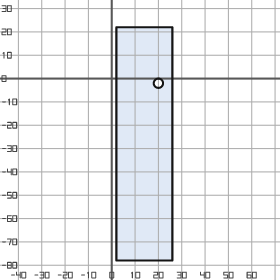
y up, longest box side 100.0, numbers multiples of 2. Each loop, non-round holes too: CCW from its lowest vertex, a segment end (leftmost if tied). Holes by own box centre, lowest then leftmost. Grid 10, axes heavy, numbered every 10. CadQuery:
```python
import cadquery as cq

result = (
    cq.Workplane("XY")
    .moveTo(2.0, -78.0)
    .lineTo(26.0, -78.0)
    .lineTo(26.0, 22.0)
    .lineTo(2.0, 22.0)
    .close()
    .moveTo(20.0, -2.0)
    .circle(2.0)
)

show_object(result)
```